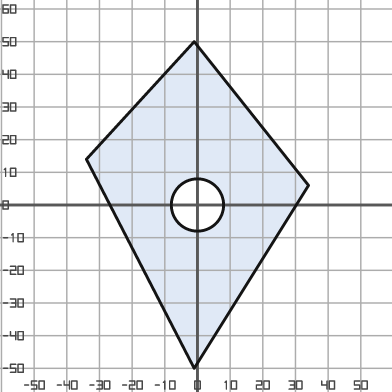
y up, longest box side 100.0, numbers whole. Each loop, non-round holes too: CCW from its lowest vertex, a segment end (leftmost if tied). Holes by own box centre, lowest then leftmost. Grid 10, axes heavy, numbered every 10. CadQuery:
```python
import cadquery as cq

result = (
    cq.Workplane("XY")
    .moveTo(-1.0, -50.0)
    .lineTo(34.0, 6.0)
    .lineTo(-1.0, 50.0)
    .lineTo(-34.0, 14.0)
    .close()
    .moveTo(0.0, 0.0)
    .circle(8.0)
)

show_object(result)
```